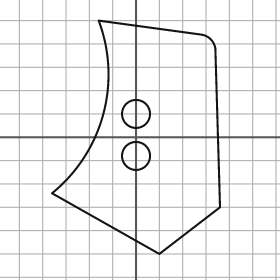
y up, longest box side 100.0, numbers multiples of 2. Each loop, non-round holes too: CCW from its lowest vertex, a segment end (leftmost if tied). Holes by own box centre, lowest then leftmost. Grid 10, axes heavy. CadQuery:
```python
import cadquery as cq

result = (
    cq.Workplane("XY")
    .moveTo(10.0, -50.0)
    .lineTo(36.0, -30.0)
    .lineTo(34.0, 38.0)
    .threePointArc((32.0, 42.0), (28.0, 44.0))
    .lineTo(-16.0, 50.0)
    .threePointArc((-14.0, 10.0), (-36.0, -24.0))
    .close()
    .moveTo(0.0, -8.0)
    .circle(6.0)
    .moveTo(0.0, 10.0)
    .circle(6.0)
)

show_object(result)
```